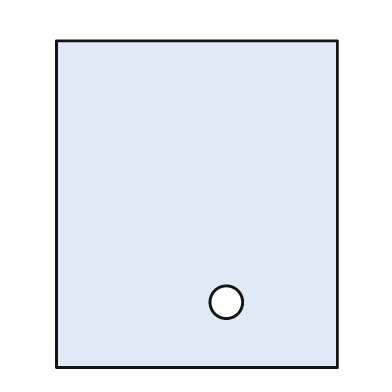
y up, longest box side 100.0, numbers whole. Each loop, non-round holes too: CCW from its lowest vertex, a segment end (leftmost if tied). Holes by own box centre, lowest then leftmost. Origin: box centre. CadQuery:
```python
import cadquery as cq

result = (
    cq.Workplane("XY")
    .moveTo(-43.0, -50.0)
    .lineTo(43.0, -50.0)
    .lineTo(43.0, 50.0)
    .lineTo(-43.0, 50.0)
    .close()
    .moveTo(9.0, -30.0)
    .circle(5.0)
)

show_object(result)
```